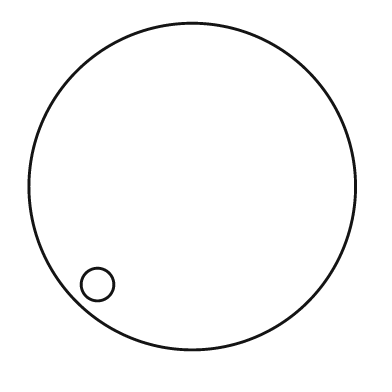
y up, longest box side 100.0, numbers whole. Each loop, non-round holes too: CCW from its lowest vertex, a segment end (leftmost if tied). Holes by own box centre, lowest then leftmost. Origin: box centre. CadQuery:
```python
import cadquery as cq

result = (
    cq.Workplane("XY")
    .moveTo(0.0, 0.0)
    .circle(50.0)
    .moveTo(-29.0, -30.0)
    .circle(5.0)
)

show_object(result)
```